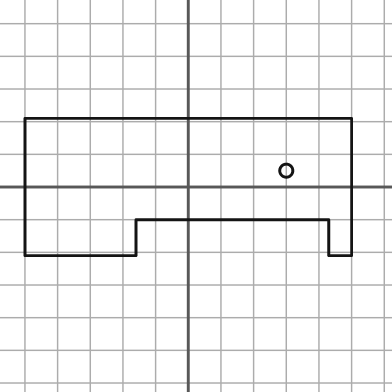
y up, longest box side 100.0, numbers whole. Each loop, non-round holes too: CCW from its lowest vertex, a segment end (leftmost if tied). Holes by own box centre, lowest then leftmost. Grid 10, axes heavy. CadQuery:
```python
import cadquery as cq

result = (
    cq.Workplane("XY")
    .moveTo(-50.0, -21.0)
    .lineTo(-16.0, -21.0)
    .lineTo(-16.0, -10.0)
    .lineTo(43.0, -10.0)
    .lineTo(43.0, -21.0)
    .lineTo(50.0, -21.0)
    .lineTo(50.0, 21.0)
    .lineTo(-50.0, 21.0)
    .close()
    .moveTo(30.0, 5.0)
    .circle(2.0)
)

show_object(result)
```